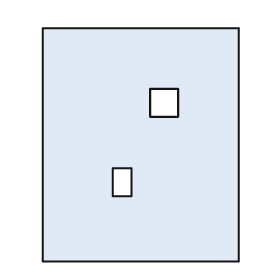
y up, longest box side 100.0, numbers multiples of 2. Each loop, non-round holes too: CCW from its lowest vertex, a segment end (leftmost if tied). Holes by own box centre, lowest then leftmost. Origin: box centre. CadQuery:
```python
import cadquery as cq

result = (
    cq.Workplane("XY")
    .moveTo(-42.0, -50.0)
    .lineTo(42.0, -50.0)
    .lineTo(42.0, 50.0)
    .lineTo(-42.0, 50.0)
    .close()
    .moveTo(-12.0, -22.0)
    .lineTo(-4.0, -22.0)
    .lineTo(-4.0, -10.0)
    .lineTo(-12.0, -10.0)
    .close()
    .moveTo(4.0, 12.0)
    .lineTo(16.0, 12.0)
    .lineTo(16.0, 24.0)
    .lineTo(4.0, 24.0)
    .close()
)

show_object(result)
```